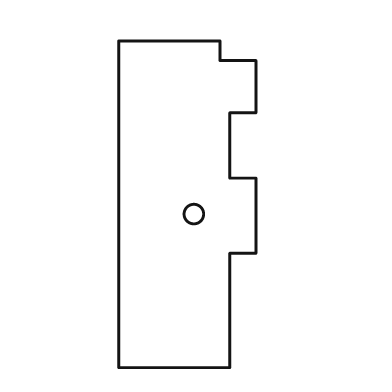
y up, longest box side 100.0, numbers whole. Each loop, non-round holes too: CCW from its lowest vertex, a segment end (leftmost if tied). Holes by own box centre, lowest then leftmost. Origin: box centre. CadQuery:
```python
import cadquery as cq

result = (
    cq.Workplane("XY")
    .moveTo(-21.0, -50.0)
    .lineTo(13.0, -50.0)
    .lineTo(13.0, -15.0)
    .lineTo(21.0, -15.0)
    .lineTo(21.0, 8.0)
    .lineTo(13.0, 8.0)
    .lineTo(13.0, 28.0)
    .lineTo(21.0, 28.0)
    .lineTo(21.0, 44.0)
    .lineTo(10.0, 44.0)
    .lineTo(10.0, 50.0)
    .lineTo(-21.0, 50.0)
    .close()
    .moveTo(2.0, -3.0)
    .circle(3.0)
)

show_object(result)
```